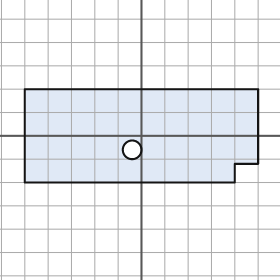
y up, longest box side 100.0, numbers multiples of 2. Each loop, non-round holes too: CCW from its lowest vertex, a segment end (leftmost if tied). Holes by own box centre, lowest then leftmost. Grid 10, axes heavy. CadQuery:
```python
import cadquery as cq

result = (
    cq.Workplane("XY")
    .moveTo(-50.0, -20.0)
    .lineTo(40.0, -20.0)
    .lineTo(40.0, -12.0)
    .lineTo(50.0, -12.0)
    .lineTo(50.0, 20.0)
    .lineTo(-50.0, 20.0)
    .close()
    .moveTo(-4.0, -6.0)
    .circle(4.0)
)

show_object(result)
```